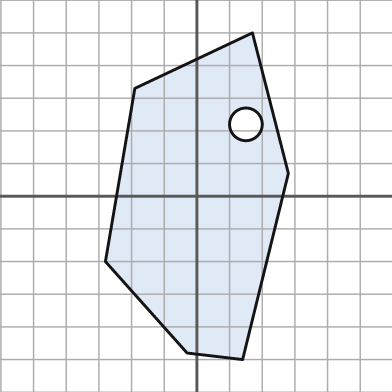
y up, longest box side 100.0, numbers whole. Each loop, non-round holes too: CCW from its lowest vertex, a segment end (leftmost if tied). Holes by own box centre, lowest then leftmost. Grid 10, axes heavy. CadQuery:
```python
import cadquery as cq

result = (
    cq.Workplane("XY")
    .moveTo(14.0, -50.0)
    .lineTo(28.0, 7.0)
    .lineTo(17.0, 50.0)
    .lineTo(-19.0, 33.0)
    .lineTo(-28.0, -20.0)
    .lineTo(-3.0, -48.0)
    .close()
    .moveTo(15.0, 22.0)
    .circle(5.0)
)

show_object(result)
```